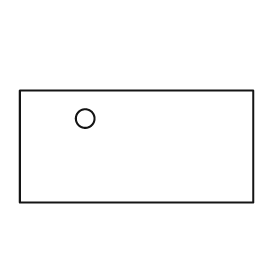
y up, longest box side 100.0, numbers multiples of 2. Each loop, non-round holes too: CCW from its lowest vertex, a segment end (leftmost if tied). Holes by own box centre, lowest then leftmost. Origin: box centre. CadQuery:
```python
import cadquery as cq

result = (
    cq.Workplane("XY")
    .moveTo(-50.0, -24.0)
    .lineTo(50.0, -24.0)
    .lineTo(50.0, 24.0)
    .lineTo(-50.0, 24.0)
    .close()
    .moveTo(-22.0, 12.0)
    .circle(4.0)
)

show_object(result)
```